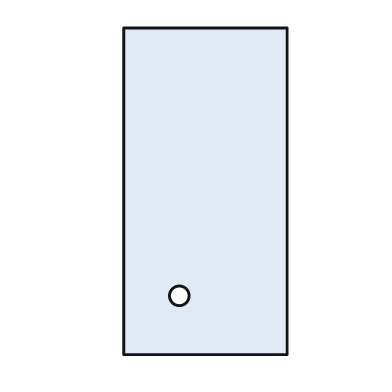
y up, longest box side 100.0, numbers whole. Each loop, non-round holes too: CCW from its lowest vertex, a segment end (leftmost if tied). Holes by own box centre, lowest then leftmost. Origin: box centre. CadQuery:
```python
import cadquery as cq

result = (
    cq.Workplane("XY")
    .moveTo(-25.0, -50.0)
    .lineTo(25.0, -50.0)
    .lineTo(25.0, 50.0)
    .lineTo(-25.0, 50.0)
    .close()
    .moveTo(-8.0, -32.0)
    .circle(3.0)
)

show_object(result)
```